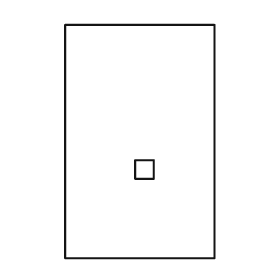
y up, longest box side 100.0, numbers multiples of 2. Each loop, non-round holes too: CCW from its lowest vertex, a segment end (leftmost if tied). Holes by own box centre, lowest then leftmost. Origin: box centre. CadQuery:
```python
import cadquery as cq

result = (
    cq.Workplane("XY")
    .moveTo(-32.0, -50.0)
    .lineTo(32.0, -50.0)
    .lineTo(32.0, 50.0)
    .lineTo(-32.0, 50.0)
    .close()
    .moveTo(-2.0, -16.0)
    .lineTo(6.0, -16.0)
    .lineTo(6.0, -8.0)
    .lineTo(-2.0, -8.0)
    .close()
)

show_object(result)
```